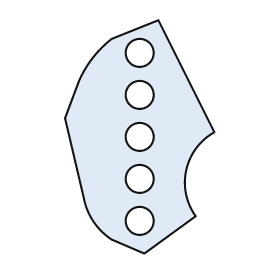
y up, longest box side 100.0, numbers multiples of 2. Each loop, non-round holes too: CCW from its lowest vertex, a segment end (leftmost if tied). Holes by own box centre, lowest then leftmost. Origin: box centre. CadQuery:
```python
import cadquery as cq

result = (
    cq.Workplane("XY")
    .moveTo(2.0, -50.0)
    .lineTo(24.0, -34.0)
    .threePointArc((20.0, -14.0), (32.0, 2.0))
    .lineTo(8.0, 50.0)
    .lineTo(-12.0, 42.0)
    .threePointArc((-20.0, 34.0), (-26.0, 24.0))
    .lineTo(-32.0, 8.0)
    .lineTo(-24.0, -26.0)
    .threePointArc((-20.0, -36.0), (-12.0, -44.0))
    .close()
    .moveTo(0.0, -36.0)
    .circle(6.0)
    .moveTo(0.0, -18.0)
    .circle(6.0)
    .moveTo(0.0, 0.0)
    .circle(6.0)
    .moveTo(0.0, 18.0)
    .circle(6.0)
    .moveTo(0.0, 36.0)
    .circle(6.0)
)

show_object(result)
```